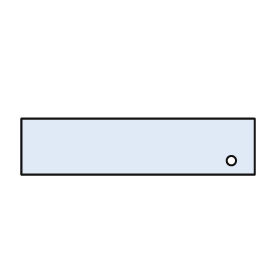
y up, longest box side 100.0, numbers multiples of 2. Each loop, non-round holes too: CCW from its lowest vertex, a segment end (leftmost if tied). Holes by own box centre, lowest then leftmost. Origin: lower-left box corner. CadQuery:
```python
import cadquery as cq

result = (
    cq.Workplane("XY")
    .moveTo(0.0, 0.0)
    .lineTo(100.0, 0.0)
    .lineTo(100.0, 24.0)
    .lineTo(0.0, 24.0)
    .close()
    .moveTo(90.0, 6.0)
    .circle(2.0)
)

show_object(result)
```